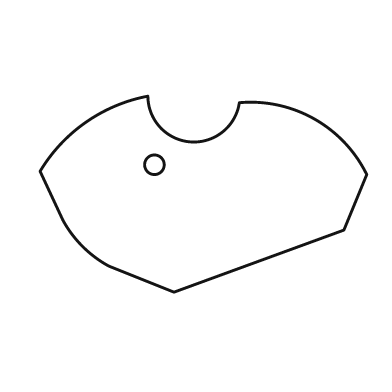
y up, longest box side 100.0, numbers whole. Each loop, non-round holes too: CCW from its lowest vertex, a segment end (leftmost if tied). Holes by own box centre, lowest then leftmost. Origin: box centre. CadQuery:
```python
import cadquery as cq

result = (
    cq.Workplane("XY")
    .moveTo(-9.0, -30.0)
    .lineTo(43.0, -11.0)
    .lineTo(50.0, 6.0)
    .threePointArc((34.0, 23.0), (11.0, 28.0))
    .threePointArc((-4.0, 16.0), (-17.0, 30.0))
    .threePointArc((-36.0, 22.0), (-50.0, 7.0))
    .lineTo(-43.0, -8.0)
    .threePointArc((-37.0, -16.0), (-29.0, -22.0))
    .close()
    .moveTo(-15.0, 9.0)
    .circle(3.0)
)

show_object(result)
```